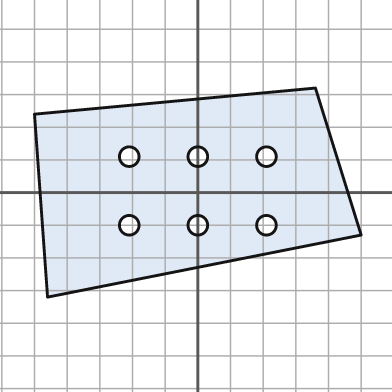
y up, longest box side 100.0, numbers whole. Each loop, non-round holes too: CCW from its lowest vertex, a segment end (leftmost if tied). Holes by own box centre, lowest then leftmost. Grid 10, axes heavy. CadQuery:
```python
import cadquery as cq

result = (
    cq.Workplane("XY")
    .moveTo(-46.0, -32.0)
    .lineTo(50.0, -13.0)
    .lineTo(36.0, 32.0)
    .lineTo(-50.0, 24.0)
    .close()
    .moveTo(-21.0, -10.0)
    .circle(3.0)
    .moveTo(0.0, -10.0)
    .circle(3.0)
    .moveTo(21.0, -10.0)
    .circle(3.0)
    .moveTo(-21.0, 11.0)
    .circle(3.0)
    .moveTo(0.0, 11.0)
    .circle(3.0)
    .moveTo(21.0, 11.0)
    .circle(3.0)
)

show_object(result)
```